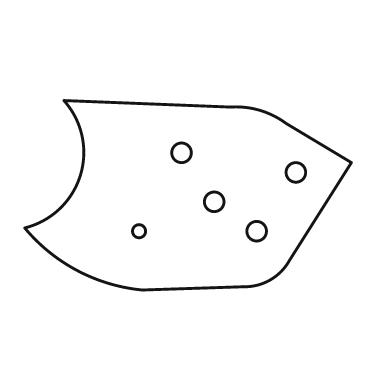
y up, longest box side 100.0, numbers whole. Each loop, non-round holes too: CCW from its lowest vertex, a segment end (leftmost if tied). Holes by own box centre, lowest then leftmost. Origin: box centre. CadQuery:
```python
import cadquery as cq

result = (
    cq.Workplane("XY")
    .moveTo(-14.0, -29.0)
    .lineTo(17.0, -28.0)
    .threePointArc((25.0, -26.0), (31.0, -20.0))
    .lineTo(50.0, 10.0)
    .lineTo(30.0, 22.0)
    .threePointArc((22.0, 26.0), (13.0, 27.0))
    .lineTo(-38.0, 29.0)
    .threePointArc((-33.0, 6.0), (-50.0, -10.0))
    .threePointArc((-34.0, -23.0), (-14.0, -29.0))
    .close()
    .moveTo(-15.0, -11.0)
    .circle(2.0)
    .moveTo(21.0, -11.0)
    .circle(3.0)
    .moveTo(8.0, -2.0)
    .circle(3.0)
    .moveTo(33.0, 7.0)
    .circle(3.0)
    .moveTo(-2.0, 13.0)
    .circle(3.0)
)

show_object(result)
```